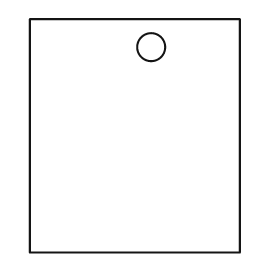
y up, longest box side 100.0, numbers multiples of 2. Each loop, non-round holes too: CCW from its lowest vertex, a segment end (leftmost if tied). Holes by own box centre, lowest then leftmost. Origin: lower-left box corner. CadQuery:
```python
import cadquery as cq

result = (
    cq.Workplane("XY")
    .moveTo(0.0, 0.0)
    .lineTo(90.0, 0.0)
    .lineTo(90.0, 100.0)
    .lineTo(0.0, 100.0)
    .close()
    .moveTo(52.0, 88.0)
    .circle(6.0)
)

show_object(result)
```